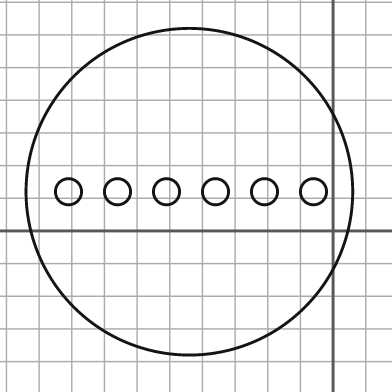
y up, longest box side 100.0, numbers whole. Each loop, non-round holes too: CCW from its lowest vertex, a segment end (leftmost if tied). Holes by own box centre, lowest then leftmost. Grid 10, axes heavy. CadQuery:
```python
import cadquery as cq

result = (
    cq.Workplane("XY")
    .moveTo(-44.0, 12.0)
    .circle(50.0)
    .moveTo(-81.0, 12.0)
    .circle(4.0)
    .moveTo(-66.0, 12.0)
    .circle(4.0)
    .moveTo(-51.0, 12.0)
    .circle(4.0)
    .moveTo(-36.0, 12.0)
    .circle(4.0)
    .moveTo(-21.0, 12.0)
    .circle(4.0)
    .moveTo(-6.0, 12.0)
    .circle(4.0)
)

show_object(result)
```